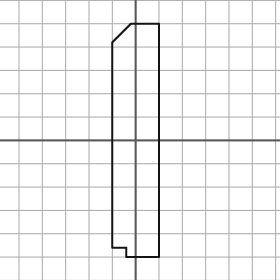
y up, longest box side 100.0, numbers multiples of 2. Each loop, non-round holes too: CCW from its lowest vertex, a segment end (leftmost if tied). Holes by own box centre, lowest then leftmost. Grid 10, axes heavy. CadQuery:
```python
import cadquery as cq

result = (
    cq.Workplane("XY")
    .moveTo(-4.0, -50.0)
    .lineTo(10.0, -50.0)
    .lineTo(10.0, 50.0)
    .lineTo(-2.0, 50.0)
    .lineTo(-10.0, 42.0)
    .lineTo(-10.0, -46.0)
    .lineTo(-4.0, -46.0)
    .close()
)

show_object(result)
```